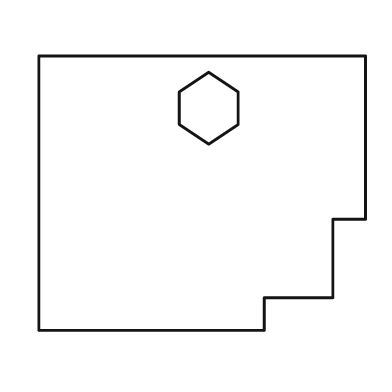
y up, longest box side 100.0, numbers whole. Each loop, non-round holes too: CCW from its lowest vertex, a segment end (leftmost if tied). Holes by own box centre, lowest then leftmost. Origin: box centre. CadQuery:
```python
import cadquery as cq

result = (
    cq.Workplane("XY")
    .moveTo(-50.0, -42.0)
    .lineTo(19.0, -42.0)
    .lineTo(19.0, -32.0)
    .lineTo(40.0, -32.0)
    .lineTo(40.0, -8.0)
    .lineTo(50.0, -8.0)
    .lineTo(50.0, 42.0)
    .lineTo(-50.0, 42.0)
    .close()
    .moveTo(2.0, 15.0)
    .lineTo(11.0, 21.0)
    .lineTo(11.0, 31.0)
    .lineTo(2.0, 37.0)
    .lineTo(-7.0, 31.0)
    .lineTo(-7.0, 21.0)
    .close()
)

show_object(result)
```